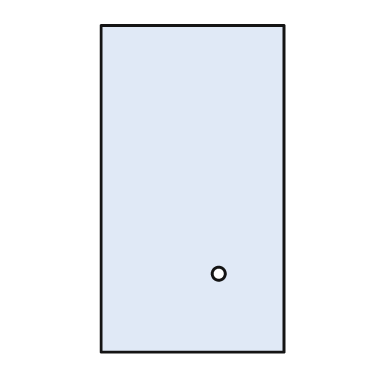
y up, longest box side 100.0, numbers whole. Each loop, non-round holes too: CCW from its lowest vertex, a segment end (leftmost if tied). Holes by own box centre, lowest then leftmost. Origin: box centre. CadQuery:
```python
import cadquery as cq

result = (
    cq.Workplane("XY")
    .moveTo(-28.0, -50.0)
    .lineTo(28.0, -50.0)
    .lineTo(28.0, 50.0)
    .lineTo(-28.0, 50.0)
    .close()
    .moveTo(8.0, -26.0)
    .circle(2.0)
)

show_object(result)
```